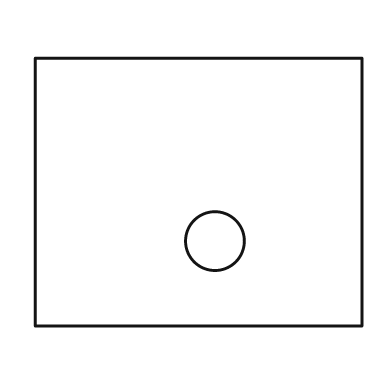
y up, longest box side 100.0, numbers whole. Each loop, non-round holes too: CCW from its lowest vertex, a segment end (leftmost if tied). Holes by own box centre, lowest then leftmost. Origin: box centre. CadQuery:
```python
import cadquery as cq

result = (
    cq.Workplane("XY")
    .moveTo(-50.0, -41.0)
    .lineTo(50.0, -41.0)
    .lineTo(50.0, 41.0)
    .lineTo(-50.0, 41.0)
    .close()
    .moveTo(5.0, -15.0)
    .circle(9.0)
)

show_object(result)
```